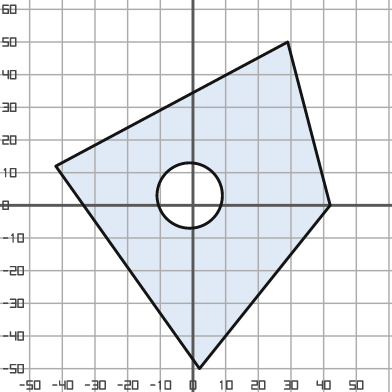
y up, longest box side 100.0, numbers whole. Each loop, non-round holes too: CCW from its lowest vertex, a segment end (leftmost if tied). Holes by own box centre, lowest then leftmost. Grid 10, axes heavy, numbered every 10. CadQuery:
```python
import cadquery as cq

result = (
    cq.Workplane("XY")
    .moveTo(2.0, -50.0)
    .lineTo(42.0, 0.0)
    .lineTo(29.0, 50.0)
    .lineTo(-42.0, 12.0)
    .close()
    .moveTo(-1.0, 3.0)
    .circle(10.0)
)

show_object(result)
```